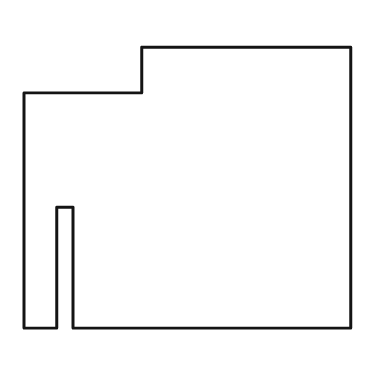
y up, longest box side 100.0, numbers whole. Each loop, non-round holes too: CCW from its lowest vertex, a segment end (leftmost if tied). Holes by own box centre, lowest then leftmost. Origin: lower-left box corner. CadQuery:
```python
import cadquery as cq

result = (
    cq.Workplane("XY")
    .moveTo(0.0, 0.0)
    .lineTo(10.0, 0.0)
    .lineTo(10.0, 37.0)
    .lineTo(15.0, 37.0)
    .lineTo(15.0, 0.0)
    .lineTo(100.0, 0.0)
    .lineTo(100.0, 86.0)
    .lineTo(36.0, 86.0)
    .lineTo(36.0, 72.0)
    .lineTo(0.0, 72.0)
    .close()
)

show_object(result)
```